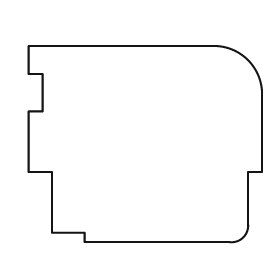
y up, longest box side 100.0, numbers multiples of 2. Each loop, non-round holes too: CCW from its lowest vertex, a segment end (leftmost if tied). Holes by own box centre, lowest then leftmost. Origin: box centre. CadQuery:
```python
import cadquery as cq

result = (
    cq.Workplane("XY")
    .moveTo(-26.0, -42.0)
    .lineTo(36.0, -42.0)
    .threePointArc((42.0, -40.0), (44.0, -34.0))
    .lineTo(44.0, -12.0)
    .lineTo(50.0, -12.0)
    .lineTo(50.0, 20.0)
    .threePointArc((44.0, 36.0), (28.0, 42.0))
    .lineTo(-50.0, 42.0)
    .lineTo(-50.0, 30.0)
    .lineTo(-44.0, 30.0)
    .lineTo(-44.0, 14.0)
    .lineTo(-50.0, 14.0)
    .lineTo(-50.0, -12.0)
    .lineTo(-40.0, -12.0)
    .lineTo(-40.0, -38.0)
    .lineTo(-26.0, -38.0)
    .close()
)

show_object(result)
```